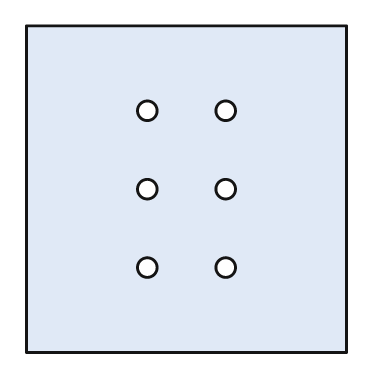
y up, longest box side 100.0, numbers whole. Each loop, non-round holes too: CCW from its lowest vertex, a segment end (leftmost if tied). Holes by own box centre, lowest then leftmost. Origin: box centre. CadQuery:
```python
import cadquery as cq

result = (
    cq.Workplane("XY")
    .moveTo(-49.0, -50.0)
    .lineTo(49.0, -50.0)
    .lineTo(49.0, 50.0)
    .lineTo(-49.0, 50.0)
    .close()
    .moveTo(-12.0, -24.0)
    .circle(3.0)
    .moveTo(12.0, -24.0)
    .circle(3.0)
    .moveTo(-12.0, 0.0)
    .circle(3.0)
    .moveTo(12.0, 0.0)
    .circle(3.0)
    .moveTo(-12.0, 24.0)
    .circle(3.0)
    .moveTo(12.0, 24.0)
    .circle(3.0)
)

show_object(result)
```